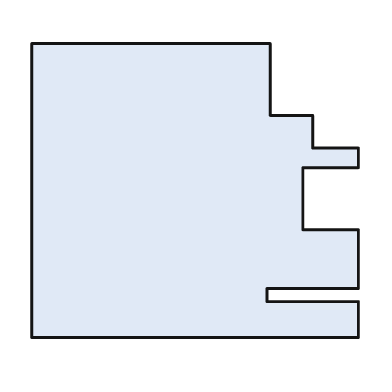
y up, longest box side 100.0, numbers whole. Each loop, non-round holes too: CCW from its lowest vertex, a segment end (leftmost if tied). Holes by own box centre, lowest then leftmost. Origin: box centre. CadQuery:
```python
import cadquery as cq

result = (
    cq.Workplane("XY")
    .moveTo(-50.0, -45.0)
    .lineTo(50.0, -45.0)
    .lineTo(50.0, -34.0)
    .lineTo(22.0, -34.0)
    .lineTo(22.0, -30.0)
    .lineTo(50.0, -30.0)
    .lineTo(50.0, -12.0)
    .lineTo(33.0, -12.0)
    .lineTo(33.0, 7.0)
    .lineTo(50.0, 7.0)
    .lineTo(50.0, 13.0)
    .lineTo(36.0, 13.0)
    .lineTo(36.0, 23.0)
    .lineTo(23.0, 23.0)
    .lineTo(23.0, 45.0)
    .lineTo(-50.0, 45.0)
    .close()
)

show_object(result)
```